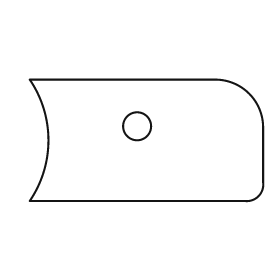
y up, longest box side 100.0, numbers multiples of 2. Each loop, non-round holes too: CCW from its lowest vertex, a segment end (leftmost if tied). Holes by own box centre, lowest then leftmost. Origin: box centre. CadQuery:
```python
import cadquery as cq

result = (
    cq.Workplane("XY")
    .moveTo(-50.0, -26.0)
    .lineTo(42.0, -26.0)
    .threePointArc((48.0, -24.0), (50.0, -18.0))
    .lineTo(50.0, 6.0)
    .threePointArc((44.0, 20.0), (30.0, 26.0))
    .lineTo(-50.0, 26.0)
    .threePointArc((-42.0, 0.0), (-50.0, -26.0))
    .close()
    .moveTo(-4.0, 6.0)
    .circle(6.0)
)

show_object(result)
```